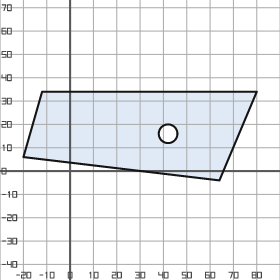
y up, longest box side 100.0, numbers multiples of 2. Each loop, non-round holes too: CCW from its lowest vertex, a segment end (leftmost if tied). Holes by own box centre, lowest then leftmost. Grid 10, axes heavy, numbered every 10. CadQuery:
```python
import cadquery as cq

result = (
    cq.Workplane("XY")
    .moveTo(64.0, -4.0)
    .lineTo(80.0, 34.0)
    .lineTo(-12.0, 34.0)
    .lineTo(-20.0, 6.0)
    .close()
    .moveTo(42.0, 16.0)
    .circle(4.0)
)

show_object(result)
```